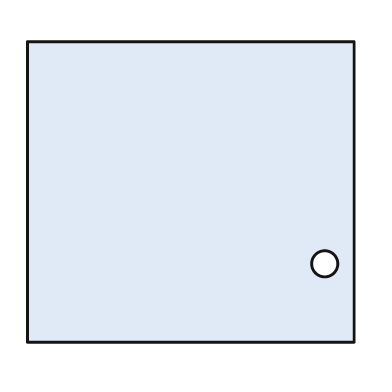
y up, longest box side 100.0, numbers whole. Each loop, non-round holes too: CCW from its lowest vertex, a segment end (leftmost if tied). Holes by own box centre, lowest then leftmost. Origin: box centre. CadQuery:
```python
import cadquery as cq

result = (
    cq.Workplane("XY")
    .moveTo(-50.0, -46.0)
    .lineTo(50.0, -46.0)
    .lineTo(50.0, 46.0)
    .lineTo(-50.0, 46.0)
    .close()
    .moveTo(41.0, -22.0)
    .circle(4.0)
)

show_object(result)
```